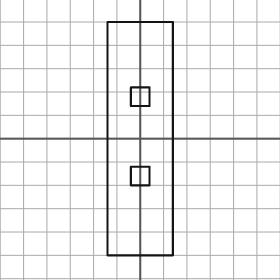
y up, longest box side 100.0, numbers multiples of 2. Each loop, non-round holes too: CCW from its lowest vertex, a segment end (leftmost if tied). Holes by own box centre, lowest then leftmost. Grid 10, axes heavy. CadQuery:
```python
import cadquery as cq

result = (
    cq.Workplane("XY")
    .moveTo(-14.0, -50.0)
    .lineTo(14.0, -50.0)
    .lineTo(14.0, 50.0)
    .lineTo(-14.0, 50.0)
    .close()
    .moveTo(-4.0, -20.0)
    .lineTo(4.0, -20.0)
    .lineTo(4.0, -12.0)
    .lineTo(-4.0, -12.0)
    .close()
    .moveTo(-4.0, 14.0)
    .lineTo(4.0, 14.0)
    .lineTo(4.0, 22.0)
    .lineTo(-4.0, 22.0)
    .close()
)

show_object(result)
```